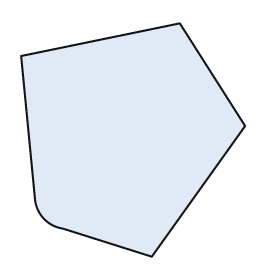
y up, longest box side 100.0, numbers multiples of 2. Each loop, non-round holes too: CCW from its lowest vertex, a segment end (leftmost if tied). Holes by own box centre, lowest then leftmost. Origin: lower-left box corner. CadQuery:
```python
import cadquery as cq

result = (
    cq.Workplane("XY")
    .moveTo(56.0, 0.0)
    .lineTo(96.0, 56.0)
    .lineTo(68.0, 100.0)
    .lineTo(0.0, 86.0)
    .lineTo(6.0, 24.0)
    .threePointArc((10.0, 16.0), (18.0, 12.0))
    .close()
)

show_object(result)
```